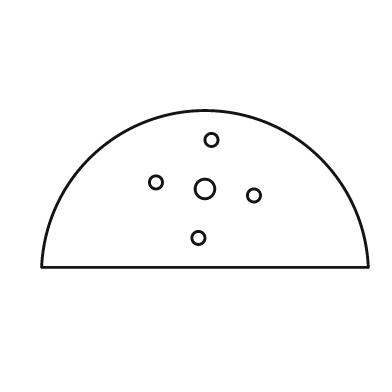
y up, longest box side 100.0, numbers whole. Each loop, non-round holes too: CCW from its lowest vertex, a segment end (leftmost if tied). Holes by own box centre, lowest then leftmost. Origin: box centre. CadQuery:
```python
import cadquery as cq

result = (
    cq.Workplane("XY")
    .moveTo(-50.0, -24.0)
    .lineTo(50.0, -24.0)
    .threePointArc((0.0, 24.0), (-50.0, -24.0))
    .close()
    .moveTo(-2.0, -15.0)
    .circle(2.0)
    .moveTo(15.0, -2.0)
    .circle(2.0)
    .moveTo(0.0, 0.0)
    .circle(3.0)
    .moveTo(-15.0, 2.0)
    .circle(2.0)
    .moveTo(2.0, 15.0)
    .circle(2.0)
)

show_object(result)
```